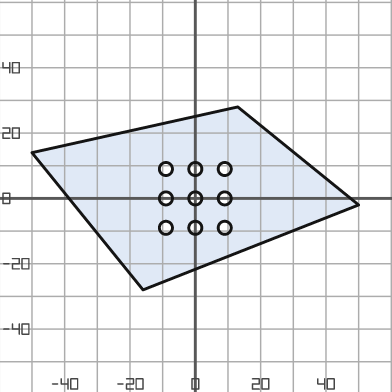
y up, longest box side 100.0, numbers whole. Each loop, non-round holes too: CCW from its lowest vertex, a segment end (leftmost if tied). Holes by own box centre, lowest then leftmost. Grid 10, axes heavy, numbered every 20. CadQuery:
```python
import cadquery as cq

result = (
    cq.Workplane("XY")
    .moveTo(-16.0, -28.0)
    .lineTo(50.0, -2.0)
    .lineTo(13.0, 28.0)
    .lineTo(-50.0, 14.0)
    .close()
    .moveTo(-9.0, -9.0)
    .circle(2.0)
    .moveTo(0.0, -9.0)
    .circle(2.0)
    .moveTo(9.0, -9.0)
    .circle(2.0)
    .moveTo(-9.0, 0.0)
    .circle(2.0)
    .moveTo(0.0, 0.0)
    .circle(2.0)
    .moveTo(9.0, 0.0)
    .circle(2.0)
    .moveTo(-9.0, 9.0)
    .circle(2.0)
    .moveTo(0.0, 9.0)
    .circle(2.0)
    .moveTo(9.0, 9.0)
    .circle(2.0)
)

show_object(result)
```